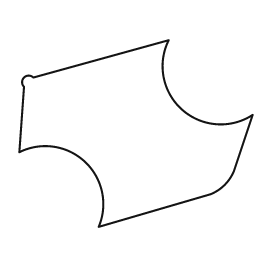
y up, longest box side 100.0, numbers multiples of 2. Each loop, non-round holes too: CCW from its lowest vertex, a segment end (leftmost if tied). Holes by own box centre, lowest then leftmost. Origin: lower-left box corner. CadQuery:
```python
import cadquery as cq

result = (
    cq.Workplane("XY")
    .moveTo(34.0, 0.0)
    .lineTo(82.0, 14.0)
    .threePointArc((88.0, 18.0), (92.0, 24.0))
    .lineTo(100.0, 48.0)
    .threePointArc((70.0, 50.0), (64.0, 80.0))
    .lineTo(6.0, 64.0)
    .threePointArc((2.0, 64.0), (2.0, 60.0))
    .lineTo(0.0, 32.0)
    .threePointArc((28.0, 28.0), (34.0, 0.0))
    .close()
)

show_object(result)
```